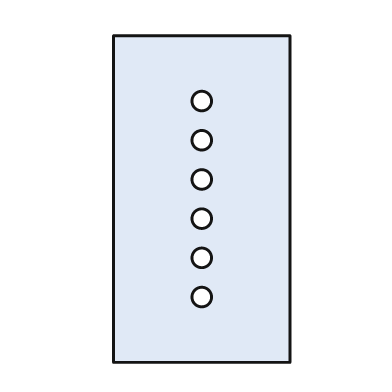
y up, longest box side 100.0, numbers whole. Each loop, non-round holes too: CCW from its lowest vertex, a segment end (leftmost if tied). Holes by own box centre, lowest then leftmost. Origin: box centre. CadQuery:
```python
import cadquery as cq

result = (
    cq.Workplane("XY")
    .moveTo(-27.0, -50.0)
    .lineTo(27.0, -50.0)
    .lineTo(27.0, 50.0)
    .lineTo(-27.0, 50.0)
    .close()
    .moveTo(0.0, -30.0)
    .circle(3.0)
    .moveTo(0.0, -18.0)
    .circle(3.0)
    .moveTo(0.0, -6.0)
    .circle(3.0)
    .moveTo(0.0, 6.0)
    .circle(3.0)
    .moveTo(0.0, 18.0)
    .circle(3.0)
    .moveTo(0.0, 30.0)
    .circle(3.0)
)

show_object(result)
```